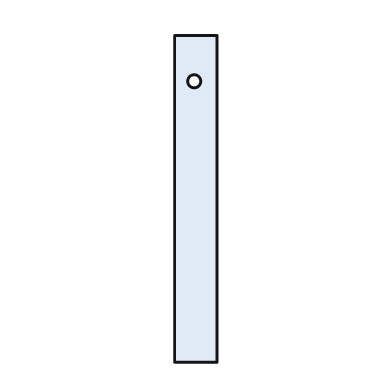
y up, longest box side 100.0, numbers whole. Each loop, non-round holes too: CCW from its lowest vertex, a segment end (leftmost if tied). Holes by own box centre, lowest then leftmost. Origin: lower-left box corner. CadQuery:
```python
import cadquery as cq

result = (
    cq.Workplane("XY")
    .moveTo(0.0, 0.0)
    .lineTo(13.0, 0.0)
    .lineTo(13.0, 100.0)
    .lineTo(0.0, 100.0)
    .close()
    .moveTo(6.0, 86.0)
    .circle(2.0)
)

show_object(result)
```